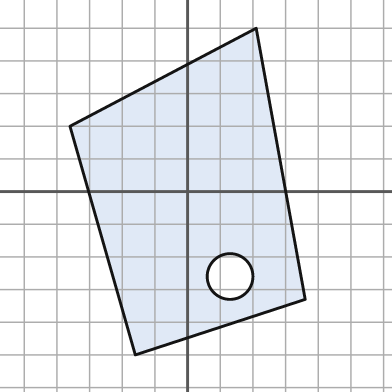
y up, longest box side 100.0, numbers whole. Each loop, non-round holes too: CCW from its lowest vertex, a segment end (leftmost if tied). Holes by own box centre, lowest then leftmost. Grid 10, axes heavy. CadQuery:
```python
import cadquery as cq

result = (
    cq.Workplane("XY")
    .moveTo(-16.0, -50.0)
    .lineTo(36.0, -33.0)
    .lineTo(21.0, 50.0)
    .lineTo(-36.0, 20.0)
    .close()
    .moveTo(13.0, -26.0)
    .circle(7.0)
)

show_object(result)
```